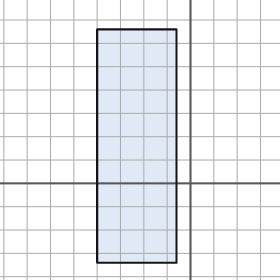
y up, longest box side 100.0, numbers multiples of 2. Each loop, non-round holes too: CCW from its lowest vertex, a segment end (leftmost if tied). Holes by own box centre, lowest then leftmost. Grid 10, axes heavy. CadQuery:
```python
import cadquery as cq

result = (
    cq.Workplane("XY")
    .moveTo(-40.0, -34.0)
    .lineTo(-6.0, -34.0)
    .lineTo(-6.0, 66.0)
    .lineTo(-40.0, 66.0)
    .close()
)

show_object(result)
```